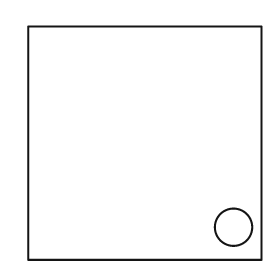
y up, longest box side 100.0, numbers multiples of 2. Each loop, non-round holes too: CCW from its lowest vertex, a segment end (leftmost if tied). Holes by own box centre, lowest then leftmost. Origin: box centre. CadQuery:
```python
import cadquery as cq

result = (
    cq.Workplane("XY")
    .moveTo(-50.0, -50.0)
    .lineTo(50.0, -50.0)
    .lineTo(50.0, 50.0)
    .lineTo(-50.0, 50.0)
    .close()
    .moveTo(38.0, -36.0)
    .circle(8.0)
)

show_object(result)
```